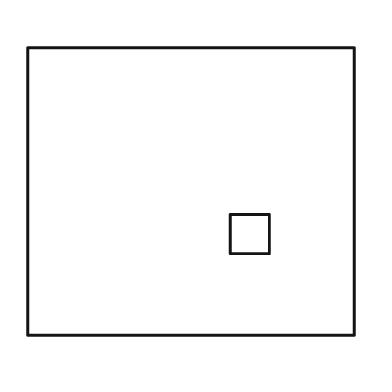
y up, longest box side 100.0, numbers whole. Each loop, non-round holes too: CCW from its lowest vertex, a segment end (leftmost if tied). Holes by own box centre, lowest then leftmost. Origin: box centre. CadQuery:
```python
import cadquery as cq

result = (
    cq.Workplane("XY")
    .moveTo(-50.0, -44.0)
    .lineTo(50.0, -44.0)
    .lineTo(50.0, 44.0)
    .lineTo(-50.0, 44.0)
    .close()
    .moveTo(12.0, -19.0)
    .lineTo(24.0, -19.0)
    .lineTo(24.0, -7.0)
    .lineTo(12.0, -7.0)
    .close()
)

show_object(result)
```